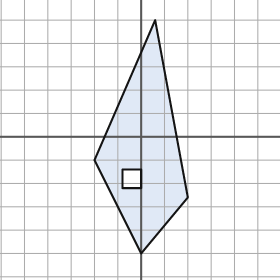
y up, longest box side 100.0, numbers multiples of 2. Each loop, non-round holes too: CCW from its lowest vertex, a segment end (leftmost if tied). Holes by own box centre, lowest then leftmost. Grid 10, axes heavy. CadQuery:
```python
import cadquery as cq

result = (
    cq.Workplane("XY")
    .moveTo(0.0, -50.0)
    .lineTo(20.0, -26.0)
    .lineTo(6.0, 50.0)
    .lineTo(-20.0, -10.0)
    .close()
    .moveTo(-8.0, -22.0)
    .lineTo(0.0, -22.0)
    .lineTo(0.0, -14.0)
    .lineTo(-8.0, -14.0)
    .close()
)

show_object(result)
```